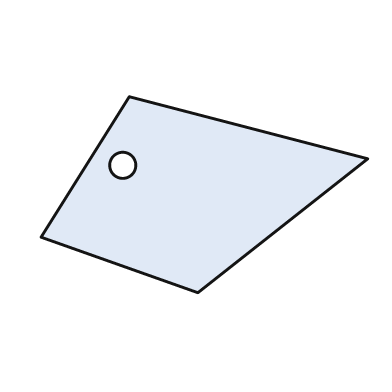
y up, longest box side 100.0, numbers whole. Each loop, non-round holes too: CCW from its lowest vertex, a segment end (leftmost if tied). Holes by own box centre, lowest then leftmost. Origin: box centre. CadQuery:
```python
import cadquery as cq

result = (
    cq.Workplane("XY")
    .moveTo(-2.0, -30.0)
    .lineTo(50.0, 11.0)
    .lineTo(-23.0, 30.0)
    .lineTo(-50.0, -13.0)
    .close()
    .moveTo(-25.0, 9.0)
    .circle(4.0)
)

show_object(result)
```